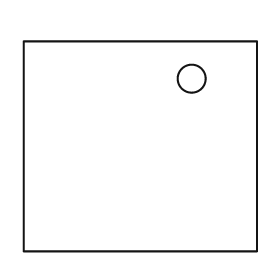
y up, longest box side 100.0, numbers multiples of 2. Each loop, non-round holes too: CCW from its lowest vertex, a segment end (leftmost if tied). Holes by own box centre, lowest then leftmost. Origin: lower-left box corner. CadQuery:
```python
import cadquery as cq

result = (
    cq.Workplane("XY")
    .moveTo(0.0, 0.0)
    .lineTo(100.0, 0.0)
    .lineTo(100.0, 90.0)
    .lineTo(0.0, 90.0)
    .close()
    .moveTo(72.0, 74.0)
    .circle(6.0)
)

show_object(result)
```